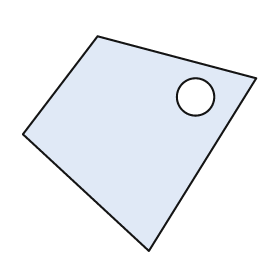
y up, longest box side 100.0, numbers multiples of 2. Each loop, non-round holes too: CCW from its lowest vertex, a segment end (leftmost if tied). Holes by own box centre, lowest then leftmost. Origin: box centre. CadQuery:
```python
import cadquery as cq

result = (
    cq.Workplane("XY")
    .moveTo(4.0, -46.0)
    .lineTo(50.0, 28.0)
    .lineTo(-18.0, 46.0)
    .lineTo(-50.0, 4.0)
    .close()
    .moveTo(24.0, 20.0)
    .circle(8.0)
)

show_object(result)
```